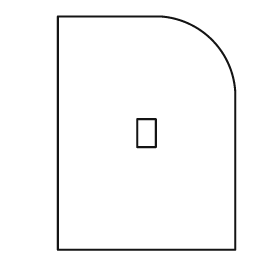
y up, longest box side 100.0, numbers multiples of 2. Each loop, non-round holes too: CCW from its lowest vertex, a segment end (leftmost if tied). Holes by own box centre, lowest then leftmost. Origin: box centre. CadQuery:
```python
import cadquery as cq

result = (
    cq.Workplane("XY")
    .moveTo(-38.0, -50.0)
    .lineTo(38.0, -50.0)
    .lineTo(38.0, 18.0)
    .threePointArc((28.0, 40.0), (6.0, 50.0))
    .lineTo(-38.0, 50.0)
    .close()
    .moveTo(-4.0, -6.0)
    .lineTo(4.0, -6.0)
    .lineTo(4.0, 6.0)
    .lineTo(-4.0, 6.0)
    .close()
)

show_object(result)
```